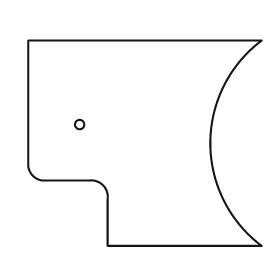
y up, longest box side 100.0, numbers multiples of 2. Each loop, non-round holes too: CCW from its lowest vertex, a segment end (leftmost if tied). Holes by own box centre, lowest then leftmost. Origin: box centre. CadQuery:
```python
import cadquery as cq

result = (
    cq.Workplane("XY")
    .moveTo(-16.0, -44.0)
    .lineTo(50.0, -44.0)
    .threePointArc((28.0, 0.0), (50.0, 44.0))
    .lineTo(-50.0, 44.0)
    .lineTo(-50.0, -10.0)
    .threePointArc((-48.0, -14.0), (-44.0, -16.0))
    .lineTo(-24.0, -16.0)
    .threePointArc((-18.0, -18.0), (-16.0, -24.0))
    .close()
    .moveTo(-28.0, 8.0)
    .circle(2.0)
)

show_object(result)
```